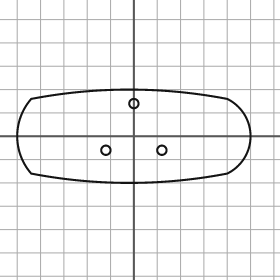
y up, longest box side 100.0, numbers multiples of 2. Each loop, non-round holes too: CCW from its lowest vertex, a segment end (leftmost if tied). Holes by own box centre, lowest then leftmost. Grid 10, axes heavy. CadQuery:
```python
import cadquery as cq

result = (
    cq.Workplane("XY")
    .moveTo(-44.0, -16.0)
    .threePointArc((-2.0, -20.0), (40.0, -16.0))
    .threePointArc((50.0, 0.0), (40.0, 16.0))
    .threePointArc((-2.0, 20.0), (-44.0, 16.0))
    .threePointArc((-50.0, 0.0), (-44.0, -16.0))
    .close()
    .moveTo(-12.0, -6.0)
    .circle(2.0)
    .moveTo(12.0, -6.0)
    .circle(2.0)
    .moveTo(0.0, 14.0)
    .circle(2.0)
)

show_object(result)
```